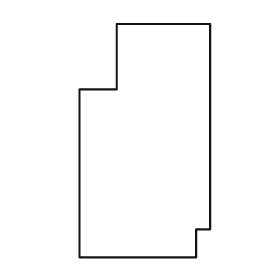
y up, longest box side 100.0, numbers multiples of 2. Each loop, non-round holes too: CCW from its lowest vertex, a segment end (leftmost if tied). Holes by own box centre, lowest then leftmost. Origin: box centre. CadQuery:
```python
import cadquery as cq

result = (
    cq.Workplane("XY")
    .moveTo(-28.0, -50.0)
    .lineTo(22.0, -50.0)
    .lineTo(22.0, -38.0)
    .lineTo(28.0, -38.0)
    .lineTo(28.0, 50.0)
    .lineTo(-12.0, 50.0)
    .lineTo(-12.0, 22.0)
    .lineTo(-28.0, 22.0)
    .close()
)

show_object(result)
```